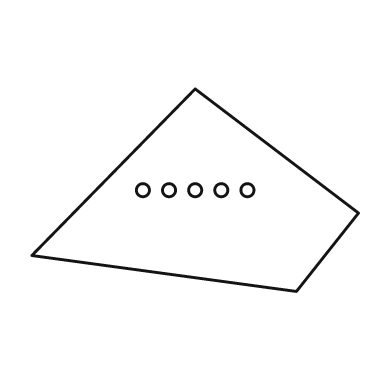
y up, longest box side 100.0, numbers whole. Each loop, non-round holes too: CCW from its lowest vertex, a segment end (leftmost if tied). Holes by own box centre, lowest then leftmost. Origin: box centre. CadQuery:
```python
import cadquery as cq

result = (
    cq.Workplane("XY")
    .moveTo(31.0, -31.0)
    .lineTo(50.0, -7.0)
    .lineTo(0.0, 31.0)
    .lineTo(-50.0, -20.0)
    .close()
    .moveTo(-16.0, 0.0)
    .circle(2.0)
    .moveTo(-8.0, 0.0)
    .circle(2.0)
    .moveTo(0.0, 0.0)
    .circle(2.0)
    .moveTo(8.0, 0.0)
    .circle(2.0)
    .moveTo(16.0, 0.0)
    .circle(2.0)
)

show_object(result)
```